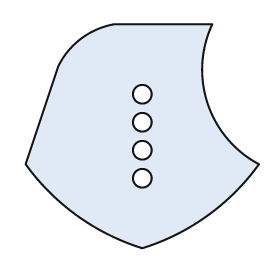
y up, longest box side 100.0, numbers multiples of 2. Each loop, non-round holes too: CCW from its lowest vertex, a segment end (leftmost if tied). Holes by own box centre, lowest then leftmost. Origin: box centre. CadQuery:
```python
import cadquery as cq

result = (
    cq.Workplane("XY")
    .moveTo(0.0, -48.0)
    .threePointArc((28.0, -34.0), (50.0, -12.0))
    .threePointArc((28.0, 14.0), (30.0, 48.0))
    .lineTo(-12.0, 48.0)
    .threePointArc((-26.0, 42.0), (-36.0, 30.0))
    .lineTo(-50.0, -12.0)
    .threePointArc((-28.0, -34.0), (0.0, -48.0))
    .close()
    .moveTo(0.0, -18.0)
    .circle(4.0)
    .moveTo(0.0, -6.0)
    .circle(4.0)
    .moveTo(0.0, 6.0)
    .circle(4.0)
    .moveTo(0.0, 18.0)
    .circle(4.0)
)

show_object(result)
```